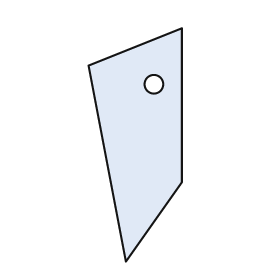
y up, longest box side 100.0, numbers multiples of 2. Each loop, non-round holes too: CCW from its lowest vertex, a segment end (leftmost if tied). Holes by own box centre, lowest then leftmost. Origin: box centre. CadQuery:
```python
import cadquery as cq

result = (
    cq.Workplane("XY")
    .moveTo(-4.0, -50.0)
    .lineTo(20.0, -16.0)
    .lineTo(20.0, 50.0)
    .lineTo(-20.0, 34.0)
    .close()
    .moveTo(8.0, 26.0)
    .circle(4.0)
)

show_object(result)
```